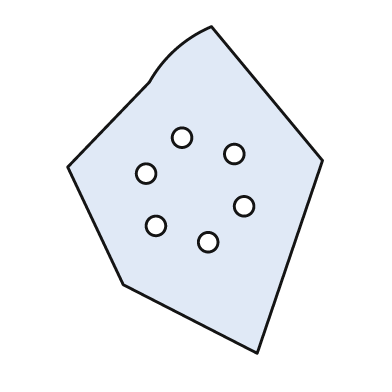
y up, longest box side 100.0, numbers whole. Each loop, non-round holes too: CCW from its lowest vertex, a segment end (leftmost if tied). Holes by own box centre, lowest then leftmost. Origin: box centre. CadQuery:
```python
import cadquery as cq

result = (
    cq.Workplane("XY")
    .moveTo(19.0, -50.0)
    .lineTo(39.0, 9.0)
    .lineTo(5.0, 50.0)
    .threePointArc((-6.0, 43.0), (-14.0, 33.0))
    .lineTo(-39.0, 7.0)
    .lineTo(-22.0, -29.0)
    .close()
    .moveTo(4.0, -16.0)
    .circle(3.0)
    .moveTo(-12.0, -11.0)
    .circle(3.0)
    .moveTo(15.0, -5.0)
    .circle(3.0)
    .moveTo(-15.0, 5.0)
    .circle(3.0)
    .moveTo(12.0, 11.0)
    .circle(3.0)
    .moveTo(-4.0, 16.0)
    .circle(3.0)
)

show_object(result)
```